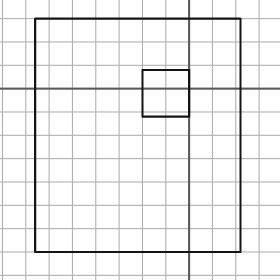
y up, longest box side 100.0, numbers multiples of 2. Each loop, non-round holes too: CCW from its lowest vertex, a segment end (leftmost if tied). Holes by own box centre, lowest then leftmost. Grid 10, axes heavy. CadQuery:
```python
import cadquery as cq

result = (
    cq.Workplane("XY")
    .moveTo(-66.0, -70.0)
    .lineTo(22.0, -70.0)
    .lineTo(22.0, 30.0)
    .lineTo(-66.0, 30.0)
    .close()
    .moveTo(-20.0, -12.0)
    .lineTo(0.0, -12.0)
    .lineTo(0.0, 8.0)
    .lineTo(-20.0, 8.0)
    .close()
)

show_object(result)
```